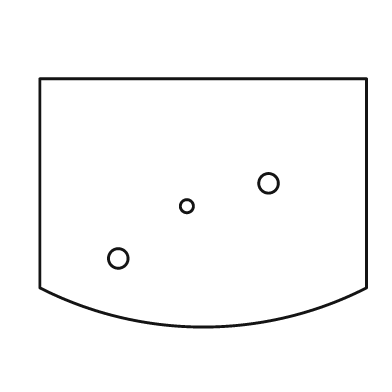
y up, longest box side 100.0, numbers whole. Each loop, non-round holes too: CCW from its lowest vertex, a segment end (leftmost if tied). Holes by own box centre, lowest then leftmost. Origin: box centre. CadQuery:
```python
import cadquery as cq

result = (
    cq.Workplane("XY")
    .moveTo(-50.0, -26.0)
    .threePointArc((0.0, -38.0), (50.0, -26.0))
    .lineTo(50.0, 38.0)
    .lineTo(-50.0, 38.0)
    .close()
    .moveTo(-26.0, -17.0)
    .circle(3.0)
    .moveTo(-5.0, -1.0)
    .circle(2.0)
    .moveTo(20.0, 6.0)
    .circle(3.0)
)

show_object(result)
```